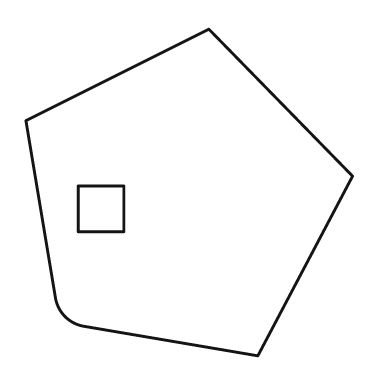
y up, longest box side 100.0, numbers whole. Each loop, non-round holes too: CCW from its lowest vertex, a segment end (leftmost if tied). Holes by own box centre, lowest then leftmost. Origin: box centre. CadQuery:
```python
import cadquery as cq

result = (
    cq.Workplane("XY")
    .moveTo(21.0, -50.0)
    .lineTo(50.0, 5.0)
    .lineTo(6.0, 50.0)
    .lineTo(-50.0, 22.0)
    .lineTo(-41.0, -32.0)
    .threePointArc((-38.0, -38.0), (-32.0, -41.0))
    .close()
    .moveTo(-34.0, -12.0)
    .lineTo(-20.0, -12.0)
    .lineTo(-20.0, 2.0)
    .lineTo(-34.0, 2.0)
    .close()
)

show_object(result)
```